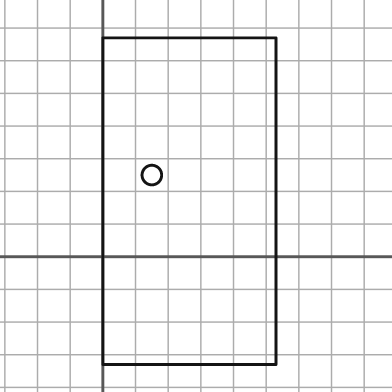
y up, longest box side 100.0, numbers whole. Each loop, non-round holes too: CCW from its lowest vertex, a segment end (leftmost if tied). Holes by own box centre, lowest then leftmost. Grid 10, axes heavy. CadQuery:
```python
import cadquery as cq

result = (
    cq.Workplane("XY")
    .moveTo(0.0, -33.0)
    .lineTo(53.0, -33.0)
    .lineTo(53.0, 67.0)
    .lineTo(0.0, 67.0)
    .close()
    .moveTo(15.0, 25.0)
    .circle(3.0)
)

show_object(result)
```